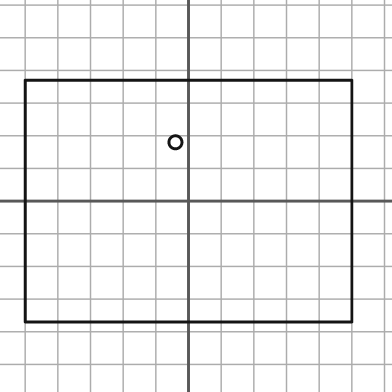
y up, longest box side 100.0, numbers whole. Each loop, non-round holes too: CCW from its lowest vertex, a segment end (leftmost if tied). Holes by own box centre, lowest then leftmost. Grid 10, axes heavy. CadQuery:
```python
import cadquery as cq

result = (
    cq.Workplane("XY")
    .moveTo(-50.0, -37.0)
    .lineTo(50.0, -37.0)
    .lineTo(50.0, 37.0)
    .lineTo(-50.0, 37.0)
    .close()
    .moveTo(-4.0, 18.0)
    .circle(2.0)
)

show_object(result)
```